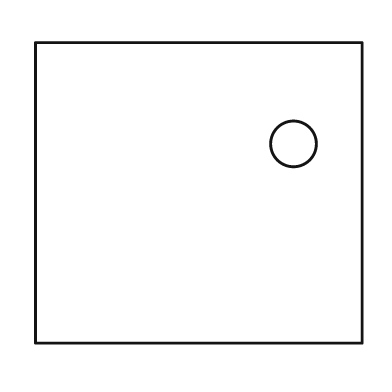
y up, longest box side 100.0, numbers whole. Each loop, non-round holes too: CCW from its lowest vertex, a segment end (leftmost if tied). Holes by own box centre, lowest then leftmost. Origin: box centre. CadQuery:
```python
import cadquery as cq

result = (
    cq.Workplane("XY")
    .moveTo(-50.0, -46.0)
    .lineTo(50.0, -46.0)
    .lineTo(50.0, 46.0)
    .lineTo(-50.0, 46.0)
    .close()
    .moveTo(29.0, 15.0)
    .circle(7.0)
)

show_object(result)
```